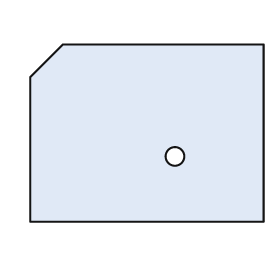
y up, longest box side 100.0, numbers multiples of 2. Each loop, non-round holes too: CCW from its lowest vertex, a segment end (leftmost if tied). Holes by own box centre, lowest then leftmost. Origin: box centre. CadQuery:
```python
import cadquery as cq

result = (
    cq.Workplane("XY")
    .moveTo(-50.0, -38.0)
    .lineTo(50.0, -38.0)
    .lineTo(50.0, 38.0)
    .lineTo(-36.0, 38.0)
    .lineTo(-50.0, 24.0)
    .close()
    .moveTo(12.0, -10.0)
    .circle(4.0)
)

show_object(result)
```